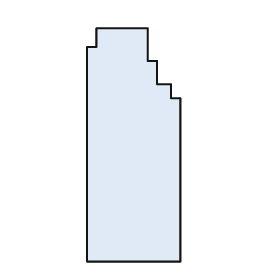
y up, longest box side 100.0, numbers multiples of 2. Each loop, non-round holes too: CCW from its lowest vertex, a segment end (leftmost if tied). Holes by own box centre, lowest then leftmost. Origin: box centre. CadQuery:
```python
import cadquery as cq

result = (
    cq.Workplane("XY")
    .moveTo(-20.0, -50.0)
    .lineTo(20.0, -50.0)
    .lineTo(20.0, 20.0)
    .lineTo(16.0, 20.0)
    .lineTo(16.0, 26.0)
    .lineTo(10.0, 26.0)
    .lineTo(10.0, 36.0)
    .lineTo(6.0, 36.0)
    .lineTo(6.0, 50.0)
    .lineTo(-16.0, 50.0)
    .lineTo(-16.0, 42.0)
    .lineTo(-20.0, 42.0)
    .close()
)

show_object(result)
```